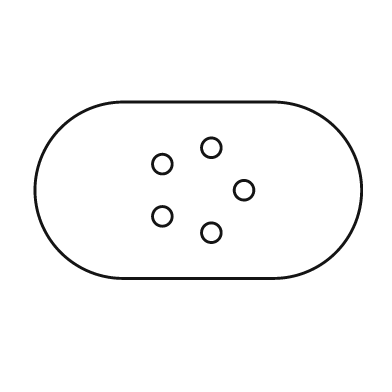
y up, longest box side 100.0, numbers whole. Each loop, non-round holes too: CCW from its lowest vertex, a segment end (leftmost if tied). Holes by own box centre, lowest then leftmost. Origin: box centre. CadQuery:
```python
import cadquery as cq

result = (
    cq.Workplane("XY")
    .moveTo(-23.0, -27.0)
    .lineTo(23.0, -27.0)
    .threePointArc((50.0, 0.0), (23.0, 27.0))
    .lineTo(-23.0, 27.0)
    .threePointArc((-50.0, 0.0), (-23.0, -27.0))
    .close()
    .moveTo(4.0, -13.0)
    .circle(3.0)
    .moveTo(-11.0, -8.0)
    .circle(3.0)
    .moveTo(14.0, 0.0)
    .circle(3.0)
    .moveTo(-11.0, 8.0)
    .circle(3.0)
    .moveTo(4.0, 13.0)
    .circle(3.0)
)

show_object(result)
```